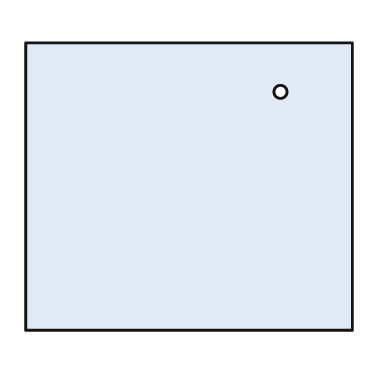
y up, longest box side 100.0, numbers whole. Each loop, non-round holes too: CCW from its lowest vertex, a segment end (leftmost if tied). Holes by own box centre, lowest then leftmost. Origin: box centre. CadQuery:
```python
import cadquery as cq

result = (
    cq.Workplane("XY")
    .moveTo(-50.0, -44.0)
    .lineTo(50.0, -44.0)
    .lineTo(50.0, 44.0)
    .lineTo(-50.0, 44.0)
    .close()
    .moveTo(28.0, 29.0)
    .circle(2.0)
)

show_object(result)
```